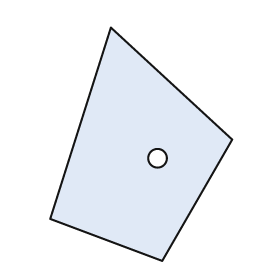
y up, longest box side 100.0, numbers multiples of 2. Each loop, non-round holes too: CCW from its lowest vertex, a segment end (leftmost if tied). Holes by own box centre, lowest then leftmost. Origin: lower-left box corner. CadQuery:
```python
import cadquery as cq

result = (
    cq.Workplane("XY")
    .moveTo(48.0, 0.0)
    .lineTo(78.0, 52.0)
    .lineTo(26.0, 100.0)
    .lineTo(0.0, 18.0)
    .close()
    .moveTo(46.0, 44.0)
    .circle(4.0)
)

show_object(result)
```